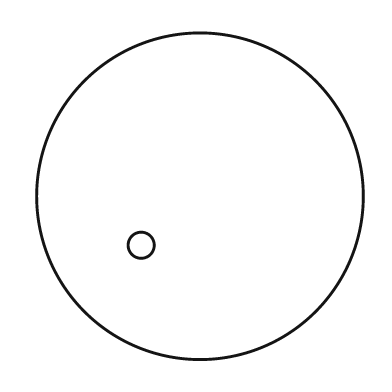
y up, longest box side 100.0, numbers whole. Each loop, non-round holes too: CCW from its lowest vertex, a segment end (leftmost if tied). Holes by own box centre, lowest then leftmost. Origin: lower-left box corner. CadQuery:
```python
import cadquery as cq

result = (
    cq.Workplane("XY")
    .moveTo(50.0, 50.0)
    .circle(50.0)
    .moveTo(32.0, 35.0)
    .circle(4.0)
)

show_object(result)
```